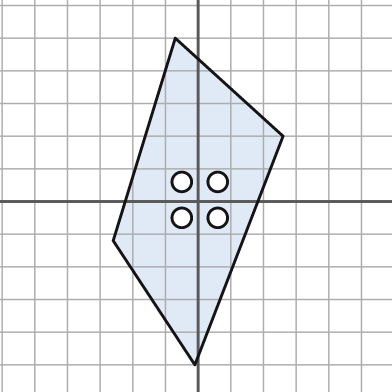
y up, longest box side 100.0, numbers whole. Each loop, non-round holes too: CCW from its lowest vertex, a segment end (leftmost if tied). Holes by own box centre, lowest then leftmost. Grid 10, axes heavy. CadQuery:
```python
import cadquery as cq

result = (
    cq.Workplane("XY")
    .moveTo(-1.0, -50.0)
    .lineTo(26.0, 20.0)
    .lineTo(-7.0, 50.0)
    .lineTo(-26.0, -12.0)
    .close()
    .moveTo(-5.0, -5.0)
    .circle(3.0)
    .moveTo(6.0, -5.0)
    .circle(3.0)
    .moveTo(-5.0, 6.0)
    .circle(3.0)
    .moveTo(6.0, 6.0)
    .circle(3.0)
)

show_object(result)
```